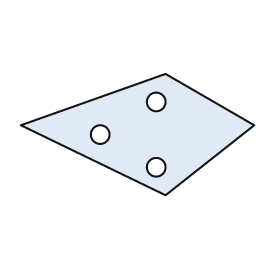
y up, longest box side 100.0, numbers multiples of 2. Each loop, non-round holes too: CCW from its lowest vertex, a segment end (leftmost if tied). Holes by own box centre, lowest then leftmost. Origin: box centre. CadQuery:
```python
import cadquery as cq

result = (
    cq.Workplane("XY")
    .moveTo(12.0, -26.0)
    .lineTo(50.0, 4.0)
    .lineTo(12.0, 26.0)
    .lineTo(-50.0, 4.0)
    .close()
    .moveTo(8.0, -14.0)
    .circle(4.0)
    .moveTo(-16.0, 0.0)
    .circle(4.0)
    .moveTo(8.0, 14.0)
    .circle(4.0)
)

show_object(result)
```